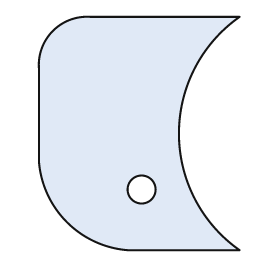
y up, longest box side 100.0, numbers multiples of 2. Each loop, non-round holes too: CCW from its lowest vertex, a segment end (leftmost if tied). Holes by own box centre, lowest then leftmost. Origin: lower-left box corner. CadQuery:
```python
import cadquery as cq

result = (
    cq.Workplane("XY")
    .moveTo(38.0, 0.0)
    .lineTo(86.0, 0.0)
    .threePointArc((60.0, 50.0), (86.0, 100.0))
    .lineTo(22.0, 100.0)
    .threePointArc((6.0, 94.0), (0.0, 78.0))
    .lineTo(0.0, 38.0)
    .threePointArc((12.0, 12.0), (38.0, 0.0))
    .close()
    .moveTo(44.0, 26.0)
    .circle(6.0)
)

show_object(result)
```